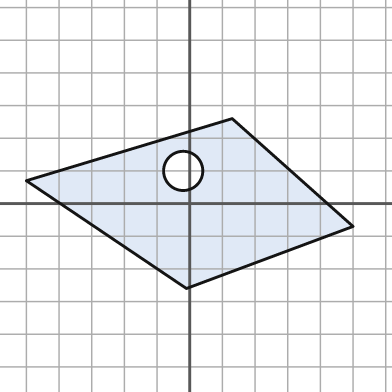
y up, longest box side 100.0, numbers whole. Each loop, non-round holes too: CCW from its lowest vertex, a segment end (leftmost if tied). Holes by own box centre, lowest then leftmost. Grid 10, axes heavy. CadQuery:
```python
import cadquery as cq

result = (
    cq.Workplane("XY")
    .moveTo(-1.0, -26.0)
    .lineTo(50.0, -7.0)
    .lineTo(13.0, 26.0)
    .lineTo(-50.0, 7.0)
    .close()
    .moveTo(-2.0, 10.0)
    .circle(6.0)
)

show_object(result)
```